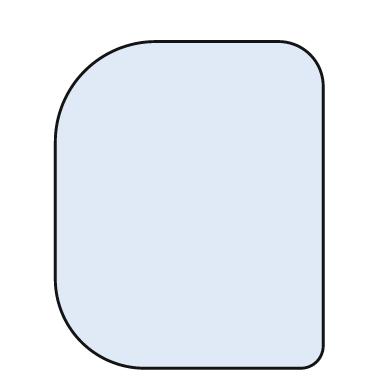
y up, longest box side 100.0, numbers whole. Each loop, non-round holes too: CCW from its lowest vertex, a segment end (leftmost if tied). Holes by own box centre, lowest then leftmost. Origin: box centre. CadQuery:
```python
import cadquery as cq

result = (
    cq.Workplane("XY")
    .moveTo(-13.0, -50.0)
    .lineTo(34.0, -50.0)
    .threePointArc((39.0, -48.0), (41.0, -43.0))
    .lineTo(41.0, 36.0)
    .threePointArc((37.0, 46.0), (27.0, 50.0))
    .lineTo(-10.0, 50.0)
    .threePointArc((-32.0, 41.0), (-41.0, 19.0))
    .lineTo(-41.0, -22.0)
    .threePointArc((-33.0, -42.0), (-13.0, -50.0))
    .close()
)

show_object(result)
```